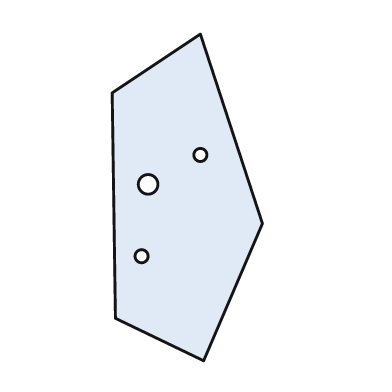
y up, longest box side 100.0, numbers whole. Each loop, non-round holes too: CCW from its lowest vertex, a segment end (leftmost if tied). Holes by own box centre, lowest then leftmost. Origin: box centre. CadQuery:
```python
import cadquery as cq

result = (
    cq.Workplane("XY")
    .moveTo(5.0, -50.0)
    .lineTo(23.0, -8.0)
    .lineTo(4.0, 50.0)
    .lineTo(-23.0, 32.0)
    .lineTo(-22.0, -37.0)
    .close()
    .moveTo(-14.0, -18.0)
    .circle(2.0)
    .moveTo(-12.0, 4.0)
    .circle(3.0)
    .moveTo(4.0, 13.0)
    .circle(2.0)
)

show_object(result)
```